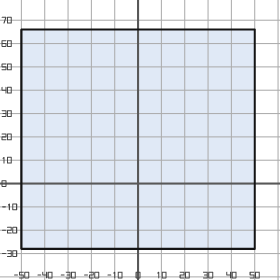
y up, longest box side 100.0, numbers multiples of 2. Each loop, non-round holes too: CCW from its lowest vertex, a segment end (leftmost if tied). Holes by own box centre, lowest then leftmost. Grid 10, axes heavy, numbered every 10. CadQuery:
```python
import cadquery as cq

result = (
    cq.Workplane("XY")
    .moveTo(-50.0, -28.0)
    .lineTo(50.0, -28.0)
    .lineTo(50.0, 66.0)
    .lineTo(-50.0, 66.0)
    .close()
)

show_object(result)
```